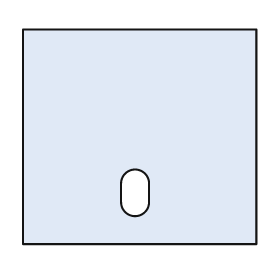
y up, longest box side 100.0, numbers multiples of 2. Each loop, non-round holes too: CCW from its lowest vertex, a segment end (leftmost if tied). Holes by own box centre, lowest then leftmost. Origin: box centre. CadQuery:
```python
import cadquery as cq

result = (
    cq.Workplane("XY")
    .moveTo(-50.0, -46.0)
    .lineTo(50.0, -46.0)
    .lineTo(50.0, 46.0)
    .lineTo(-50.0, 46.0)
    .close()
    .moveTo(-8.0, -28.0)
    .threePointArc((-2.0, -34.0), (4.0, -28.0))
    .lineTo(4.0, -20.0)
    .threePointArc((-2.0, -14.0), (-8.0, -20.0))
    .close()
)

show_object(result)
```